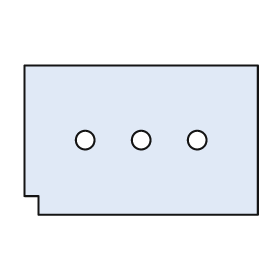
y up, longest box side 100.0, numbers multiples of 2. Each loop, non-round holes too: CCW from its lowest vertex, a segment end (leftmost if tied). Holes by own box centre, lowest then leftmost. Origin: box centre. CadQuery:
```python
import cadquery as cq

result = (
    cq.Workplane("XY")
    .moveTo(-44.0, -32.0)
    .lineTo(50.0, -32.0)
    .lineTo(50.0, 32.0)
    .lineTo(-50.0, 32.0)
    .lineTo(-50.0, -24.0)
    .lineTo(-44.0, -24.0)
    .close()
    .moveTo(-24.0, 0.0)
    .circle(4.0)
    .moveTo(0.0, 0.0)
    .circle(4.0)
    .moveTo(24.0, 0.0)
    .circle(4.0)
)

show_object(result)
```